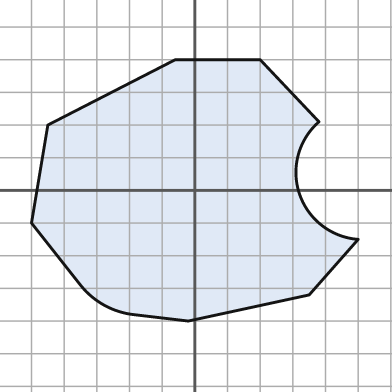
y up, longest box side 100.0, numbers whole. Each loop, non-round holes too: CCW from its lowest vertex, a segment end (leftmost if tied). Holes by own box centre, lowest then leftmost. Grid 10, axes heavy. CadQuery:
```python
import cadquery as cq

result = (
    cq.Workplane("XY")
    .moveTo(-2.0, -40.0)
    .lineTo(35.0, -32.0)
    .lineTo(50.0, -15.0)
    .threePointArc((32.0, -1.0), (38.0, 21.0))
    .lineTo(20.0, 40.0)
    .lineTo(-6.0, 40.0)
    .lineTo(-45.0, 20.0)
    .lineTo(-50.0, -10.0)
    .lineTo(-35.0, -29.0)
    .threePointArc((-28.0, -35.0), (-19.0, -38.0))
    .close()
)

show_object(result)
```